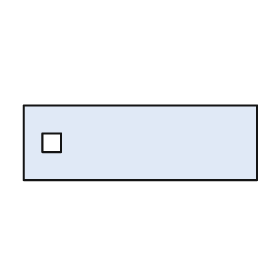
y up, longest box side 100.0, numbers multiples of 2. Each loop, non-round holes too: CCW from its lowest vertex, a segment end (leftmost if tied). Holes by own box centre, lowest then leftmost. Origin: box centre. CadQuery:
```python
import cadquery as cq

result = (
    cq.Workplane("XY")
    .moveTo(-50.0, -16.0)
    .lineTo(50.0, -16.0)
    .lineTo(50.0, 16.0)
    .lineTo(-50.0, 16.0)
    .close()
    .moveTo(-42.0, -4.0)
    .lineTo(-34.0, -4.0)
    .lineTo(-34.0, 4.0)
    .lineTo(-42.0, 4.0)
    .close()
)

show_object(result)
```